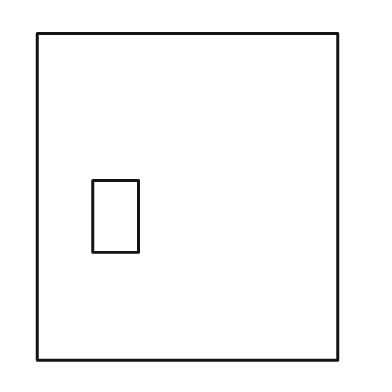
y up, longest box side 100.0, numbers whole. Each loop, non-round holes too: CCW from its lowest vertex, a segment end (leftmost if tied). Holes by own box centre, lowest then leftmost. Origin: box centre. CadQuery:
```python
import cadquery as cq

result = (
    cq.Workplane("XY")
    .moveTo(-46.0, -50.0)
    .lineTo(46.0, -50.0)
    .lineTo(46.0, 50.0)
    .lineTo(-46.0, 50.0)
    .close()
    .moveTo(-29.0, -17.0)
    .lineTo(-15.0, -17.0)
    .lineTo(-15.0, 5.0)
    .lineTo(-29.0, 5.0)
    .close()
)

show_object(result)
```